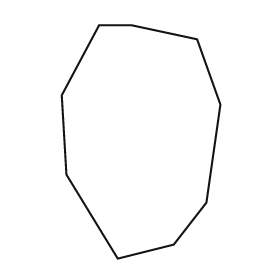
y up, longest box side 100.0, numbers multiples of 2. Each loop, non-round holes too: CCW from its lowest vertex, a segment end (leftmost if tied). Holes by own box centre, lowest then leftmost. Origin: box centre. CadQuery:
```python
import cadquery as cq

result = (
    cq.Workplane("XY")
    .moveTo(-10.0, -50.0)
    .lineTo(14.0, -44.0)
    .lineTo(28.0, -26.0)
    .lineTo(34.0, 16.0)
    .lineTo(24.0, 44.0)
    .lineTo(-4.0, 50.0)
    .lineTo(-18.0, 50.0)
    .lineTo(-34.0, 20.0)
    .lineTo(-32.0, -14.0)
    .close()
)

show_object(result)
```